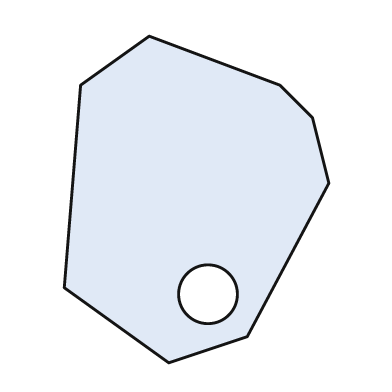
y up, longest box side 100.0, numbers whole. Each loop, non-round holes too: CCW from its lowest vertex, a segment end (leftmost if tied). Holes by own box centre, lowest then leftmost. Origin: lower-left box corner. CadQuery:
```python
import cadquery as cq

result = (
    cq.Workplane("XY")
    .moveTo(32.0, 0.0)
    .lineTo(56.0, 8.0)
    .lineTo(81.0, 55.0)
    .lineTo(76.0, 75.0)
    .lineTo(66.0, 85.0)
    .lineTo(26.0, 100.0)
    .lineTo(5.0, 85.0)
    .lineTo(0.0, 23.0)
    .close()
    .moveTo(44.0, 21.0)
    .circle(9.0)
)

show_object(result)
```